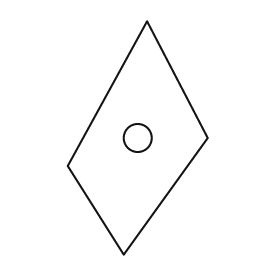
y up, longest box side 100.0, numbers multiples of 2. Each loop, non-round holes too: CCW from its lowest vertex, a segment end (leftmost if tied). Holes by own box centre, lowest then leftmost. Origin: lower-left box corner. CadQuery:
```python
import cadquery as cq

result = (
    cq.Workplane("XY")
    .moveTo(24.0, 0.0)
    .lineTo(60.0, 50.0)
    .lineTo(34.0, 100.0)
    .lineTo(0.0, 38.0)
    .close()
    .moveTo(30.0, 50.0)
    .circle(6.0)
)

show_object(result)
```